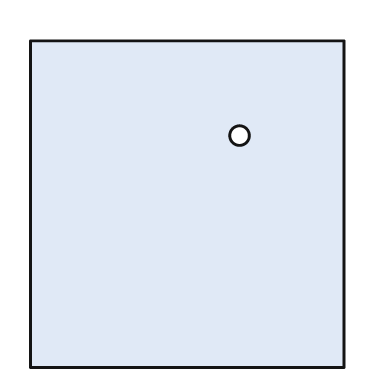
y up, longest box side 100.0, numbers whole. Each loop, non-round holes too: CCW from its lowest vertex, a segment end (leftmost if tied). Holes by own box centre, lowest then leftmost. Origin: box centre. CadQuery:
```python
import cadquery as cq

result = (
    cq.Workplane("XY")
    .moveTo(-48.0, -50.0)
    .lineTo(48.0, -50.0)
    .lineTo(48.0, 50.0)
    .lineTo(-48.0, 50.0)
    .close()
    .moveTo(16.0, 21.0)
    .circle(3.0)
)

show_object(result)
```